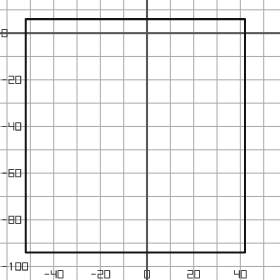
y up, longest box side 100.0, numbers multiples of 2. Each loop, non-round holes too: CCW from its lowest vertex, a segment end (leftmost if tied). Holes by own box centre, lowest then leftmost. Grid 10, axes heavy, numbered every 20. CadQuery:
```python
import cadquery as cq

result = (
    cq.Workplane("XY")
    .moveTo(-52.0, -94.0)
    .lineTo(42.0, -94.0)
    .lineTo(42.0, 6.0)
    .lineTo(-52.0, 6.0)
    .close()
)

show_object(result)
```